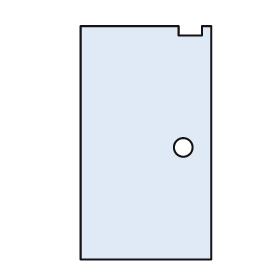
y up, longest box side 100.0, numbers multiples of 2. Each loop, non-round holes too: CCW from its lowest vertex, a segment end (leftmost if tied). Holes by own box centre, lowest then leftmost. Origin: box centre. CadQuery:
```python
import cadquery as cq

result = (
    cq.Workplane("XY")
    .moveTo(-28.0, -50.0)
    .lineTo(28.0, -50.0)
    .lineTo(28.0, 50.0)
    .lineTo(24.0, 50.0)
    .lineTo(24.0, 46.0)
    .lineTo(14.0, 46.0)
    .lineTo(14.0, 50.0)
    .lineTo(-28.0, 50.0)
    .close()
    .moveTo(16.0, -2.0)
    .circle(4.0)
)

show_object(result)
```